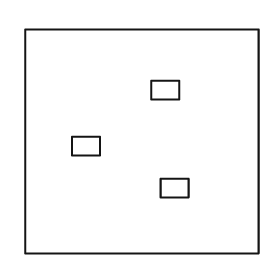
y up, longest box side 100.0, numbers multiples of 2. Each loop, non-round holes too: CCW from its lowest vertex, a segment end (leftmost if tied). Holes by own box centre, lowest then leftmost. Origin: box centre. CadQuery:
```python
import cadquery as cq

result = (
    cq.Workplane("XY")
    .moveTo(-50.0, -48.0)
    .lineTo(50.0, -48.0)
    .lineTo(50.0, 48.0)
    .lineTo(-50.0, 48.0)
    .close()
    .moveTo(8.0, -24.0)
    .lineTo(20.0, -24.0)
    .lineTo(20.0, -16.0)
    .lineTo(8.0, -16.0)
    .close()
    .moveTo(-30.0, -6.0)
    .lineTo(-18.0, -6.0)
    .lineTo(-18.0, 2.0)
    .lineTo(-30.0, 2.0)
    .close()
    .moveTo(4.0, 18.0)
    .lineTo(16.0, 18.0)
    .lineTo(16.0, 26.0)
    .lineTo(4.0, 26.0)
    .close()
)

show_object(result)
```